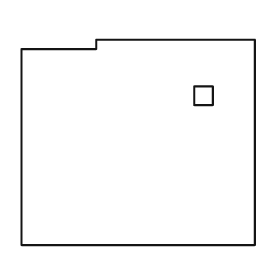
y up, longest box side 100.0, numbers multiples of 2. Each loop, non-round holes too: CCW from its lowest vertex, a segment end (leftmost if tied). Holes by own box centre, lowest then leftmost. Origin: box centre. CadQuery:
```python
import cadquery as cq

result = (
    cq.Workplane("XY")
    .moveTo(-50.0, -44.0)
    .lineTo(50.0, -44.0)
    .lineTo(50.0, 44.0)
    .lineTo(-18.0, 44.0)
    .lineTo(-18.0, 40.0)
    .lineTo(-50.0, 40.0)
    .close()
    .moveTo(24.0, 16.0)
    .lineTo(32.0, 16.0)
    .lineTo(32.0, 24.0)
    .lineTo(24.0, 24.0)
    .close()
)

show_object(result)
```